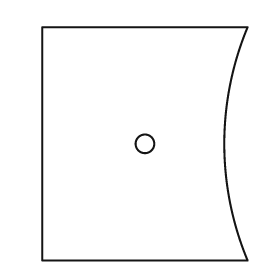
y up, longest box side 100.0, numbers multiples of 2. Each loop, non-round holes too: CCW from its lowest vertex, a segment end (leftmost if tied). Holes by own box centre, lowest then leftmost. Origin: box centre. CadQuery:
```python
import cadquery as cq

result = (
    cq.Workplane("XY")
    .moveTo(-44.0, -50.0)
    .lineTo(44.0, -50.0)
    .threePointArc((34.0, 0.0), (44.0, 50.0))
    .lineTo(-44.0, 50.0)
    .close()
    .moveTo(0.0, 0.0)
    .circle(4.0)
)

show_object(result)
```